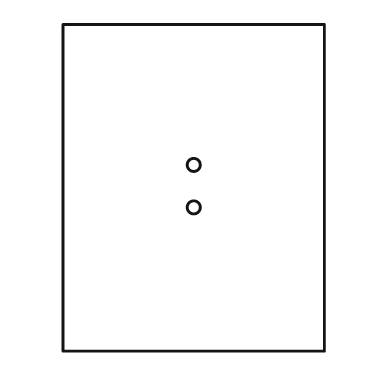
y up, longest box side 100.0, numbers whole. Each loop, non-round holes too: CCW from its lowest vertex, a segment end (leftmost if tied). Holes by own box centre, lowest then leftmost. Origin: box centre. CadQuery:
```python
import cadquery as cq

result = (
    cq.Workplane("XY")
    .moveTo(-40.0, -50.0)
    .lineTo(40.0, -50.0)
    .lineTo(40.0, 50.0)
    .lineTo(-40.0, 50.0)
    .close()
    .moveTo(0.0, -6.0)
    .circle(2.0)
    .moveTo(0.0, 7.0)
    .circle(2.0)
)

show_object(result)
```